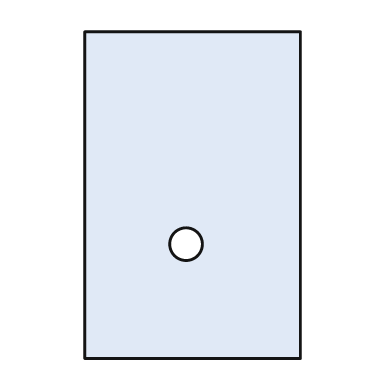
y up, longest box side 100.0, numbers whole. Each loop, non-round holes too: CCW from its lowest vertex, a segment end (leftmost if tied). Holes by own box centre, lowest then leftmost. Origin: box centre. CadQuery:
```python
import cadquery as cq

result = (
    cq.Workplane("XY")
    .moveTo(-33.0, -50.0)
    .lineTo(33.0, -50.0)
    .lineTo(33.0, 50.0)
    .lineTo(-33.0, 50.0)
    .close()
    .moveTo(-2.0, -15.0)
    .circle(5.0)
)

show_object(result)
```